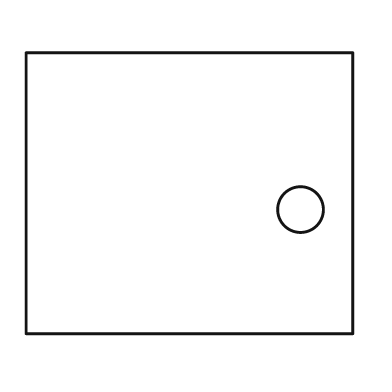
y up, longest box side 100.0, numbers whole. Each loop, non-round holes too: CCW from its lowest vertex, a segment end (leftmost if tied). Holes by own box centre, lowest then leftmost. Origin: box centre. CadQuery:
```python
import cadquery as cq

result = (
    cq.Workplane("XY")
    .moveTo(-50.0, -43.0)
    .lineTo(50.0, -43.0)
    .lineTo(50.0, 43.0)
    .lineTo(-50.0, 43.0)
    .close()
    .moveTo(34.0, -5.0)
    .circle(7.0)
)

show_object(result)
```